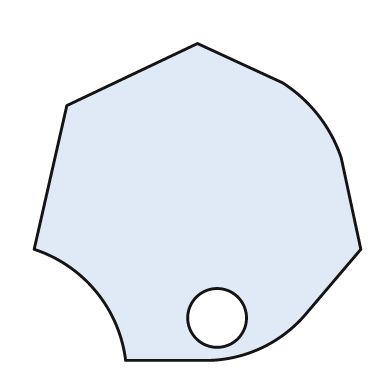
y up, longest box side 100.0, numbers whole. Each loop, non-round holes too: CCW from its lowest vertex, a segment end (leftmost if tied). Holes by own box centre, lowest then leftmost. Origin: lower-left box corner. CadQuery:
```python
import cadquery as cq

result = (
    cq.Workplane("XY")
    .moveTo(28.0, 0.0)
    .lineTo(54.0, 0.0)
    .threePointArc((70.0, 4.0), (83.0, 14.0))
    .lineTo(100.0, 34.0)
    .lineTo(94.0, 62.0)
    .threePointArc((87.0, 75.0), (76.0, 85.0))
    .lineTo(50.0, 97.0)
    .lineTo(10.0, 78.0)
    .lineTo(0.0, 34.0)
    .threePointArc((19.0, 21.0), (28.0, 0.0))
    .close()
    .moveTo(56.0, 13.0)
    .circle(9.0)
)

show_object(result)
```